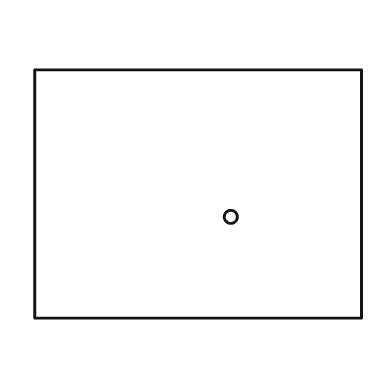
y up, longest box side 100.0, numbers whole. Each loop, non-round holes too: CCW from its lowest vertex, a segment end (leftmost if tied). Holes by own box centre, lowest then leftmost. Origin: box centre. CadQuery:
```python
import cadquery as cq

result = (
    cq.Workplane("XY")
    .moveTo(-50.0, -38.0)
    .lineTo(50.0, -38.0)
    .lineTo(50.0, 38.0)
    .lineTo(-50.0, 38.0)
    .close()
    .moveTo(10.0, -7.0)
    .circle(2.0)
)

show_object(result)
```